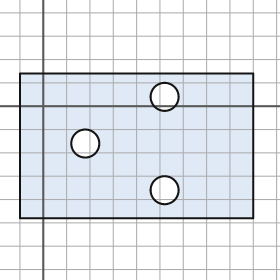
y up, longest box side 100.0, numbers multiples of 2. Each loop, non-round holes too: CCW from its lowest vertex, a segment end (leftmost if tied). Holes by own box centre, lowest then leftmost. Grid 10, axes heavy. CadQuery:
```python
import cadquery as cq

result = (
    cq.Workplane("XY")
    .moveTo(-10.0, -48.0)
    .lineTo(90.0, -48.0)
    .lineTo(90.0, 14.0)
    .lineTo(-10.0, 14.0)
    .close()
    .moveTo(52.0, -36.0)
    .circle(6.0)
    .moveTo(18.0, -16.0)
    .circle(6.0)
    .moveTo(52.0, 4.0)
    .circle(6.0)
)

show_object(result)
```